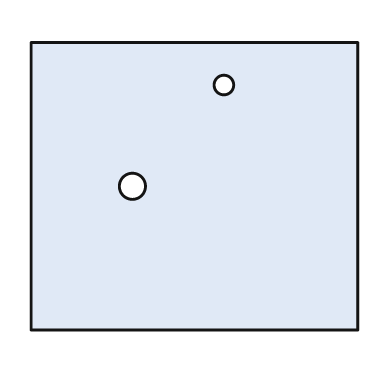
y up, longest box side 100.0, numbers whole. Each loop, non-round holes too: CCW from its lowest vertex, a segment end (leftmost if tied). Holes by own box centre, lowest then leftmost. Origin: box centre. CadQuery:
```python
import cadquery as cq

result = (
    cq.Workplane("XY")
    .moveTo(-50.0, -44.0)
    .lineTo(50.0, -44.0)
    .lineTo(50.0, 44.0)
    .lineTo(-50.0, 44.0)
    .close()
    .moveTo(-19.0, 0.0)
    .circle(4.0)
    .moveTo(9.0, 31.0)
    .circle(3.0)
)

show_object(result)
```